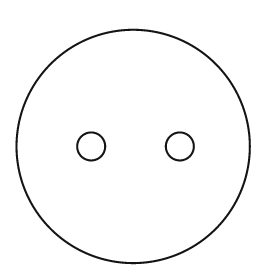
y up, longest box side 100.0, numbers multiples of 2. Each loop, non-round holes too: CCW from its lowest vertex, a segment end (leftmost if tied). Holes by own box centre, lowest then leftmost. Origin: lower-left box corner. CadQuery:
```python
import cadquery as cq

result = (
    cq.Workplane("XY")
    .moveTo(50.0, 50.0)
    .circle(50.0)
    .moveTo(32.0, 50.0)
    .circle(6.0)
    .moveTo(70.0, 50.0)
    .circle(6.0)
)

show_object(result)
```